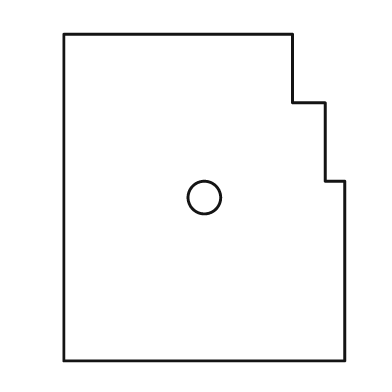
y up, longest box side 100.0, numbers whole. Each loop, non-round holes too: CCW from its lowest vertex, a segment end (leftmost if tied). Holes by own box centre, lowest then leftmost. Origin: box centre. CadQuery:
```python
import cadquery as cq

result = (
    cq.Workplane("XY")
    .moveTo(-43.0, -50.0)
    .lineTo(43.0, -50.0)
    .lineTo(43.0, 5.0)
    .lineTo(37.0, 5.0)
    .lineTo(37.0, 29.0)
    .lineTo(27.0, 29.0)
    .lineTo(27.0, 50.0)
    .lineTo(-43.0, 50.0)
    .close()
    .moveTo(0.0, 0.0)
    .circle(5.0)
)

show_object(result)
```